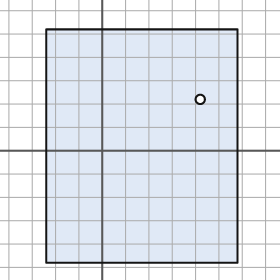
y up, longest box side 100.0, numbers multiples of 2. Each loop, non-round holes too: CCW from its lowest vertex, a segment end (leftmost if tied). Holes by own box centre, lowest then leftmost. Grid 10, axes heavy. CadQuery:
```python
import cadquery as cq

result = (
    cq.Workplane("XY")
    .moveTo(-24.0, -48.0)
    .lineTo(58.0, -48.0)
    .lineTo(58.0, 52.0)
    .lineTo(-24.0, 52.0)
    .close()
    .moveTo(42.0, 22.0)
    .circle(2.0)
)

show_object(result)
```